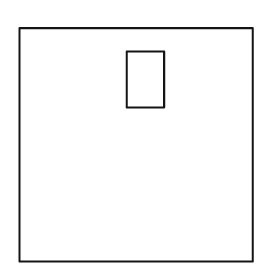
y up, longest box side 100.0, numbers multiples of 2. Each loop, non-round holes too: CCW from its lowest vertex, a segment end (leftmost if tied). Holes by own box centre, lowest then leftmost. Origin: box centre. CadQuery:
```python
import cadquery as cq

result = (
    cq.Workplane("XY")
    .moveTo(-50.0, -50.0)
    .lineTo(50.0, -50.0)
    .lineTo(50.0, 50.0)
    .lineTo(-50.0, 50.0)
    .close()
    .moveTo(-4.0, 16.0)
    .lineTo(12.0, 16.0)
    .lineTo(12.0, 40.0)
    .lineTo(-4.0, 40.0)
    .close()
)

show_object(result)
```